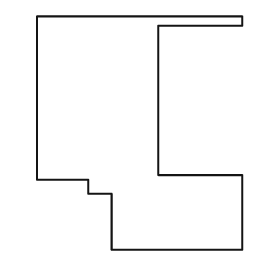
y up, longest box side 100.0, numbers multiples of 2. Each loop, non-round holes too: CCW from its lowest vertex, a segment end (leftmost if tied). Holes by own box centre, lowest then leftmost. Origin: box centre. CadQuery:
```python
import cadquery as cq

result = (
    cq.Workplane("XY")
    .moveTo(-12.0, -50.0)
    .lineTo(44.0, -50.0)
    .lineTo(44.0, -18.0)
    .lineTo(8.0, -18.0)
    .lineTo(8.0, 46.0)
    .lineTo(44.0, 46.0)
    .lineTo(44.0, 50.0)
    .lineTo(-44.0, 50.0)
    .lineTo(-44.0, -20.0)
    .lineTo(-22.0, -20.0)
    .lineTo(-22.0, -26.0)
    .lineTo(-12.0, -26.0)
    .close()
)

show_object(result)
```